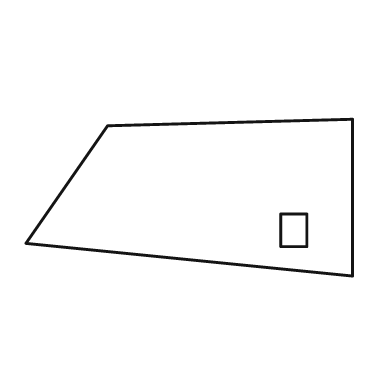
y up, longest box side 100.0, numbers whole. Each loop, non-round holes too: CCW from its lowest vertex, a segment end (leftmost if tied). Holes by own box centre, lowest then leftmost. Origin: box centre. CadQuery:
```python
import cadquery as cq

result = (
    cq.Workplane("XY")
    .moveTo(50.0, -24.0)
    .lineTo(50.0, 24.0)
    .lineTo(-25.0, 22.0)
    .lineTo(-50.0, -14.0)
    .close()
    .moveTo(28.0, -15.0)
    .lineTo(36.0, -15.0)
    .lineTo(36.0, -5.0)
    .lineTo(28.0, -5.0)
    .close()
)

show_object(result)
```